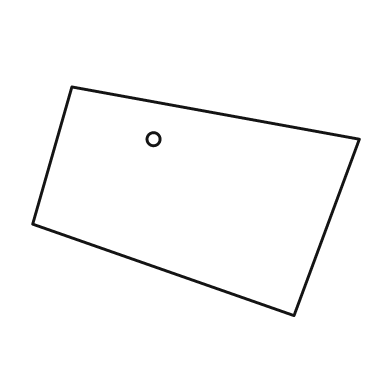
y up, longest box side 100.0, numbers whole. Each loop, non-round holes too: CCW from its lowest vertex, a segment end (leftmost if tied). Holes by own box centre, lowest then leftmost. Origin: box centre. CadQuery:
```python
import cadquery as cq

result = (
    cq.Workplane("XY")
    .moveTo(30.0, -35.0)
    .lineTo(50.0, 19.0)
    .lineTo(-38.0, 35.0)
    .lineTo(-50.0, -7.0)
    .close()
    .moveTo(-13.0, 19.0)
    .circle(2.0)
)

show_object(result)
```